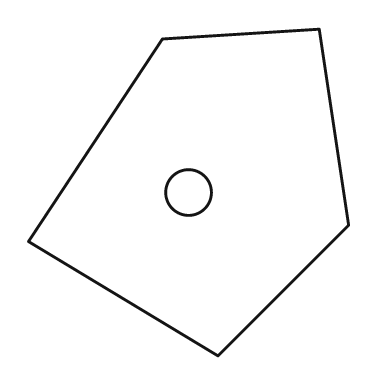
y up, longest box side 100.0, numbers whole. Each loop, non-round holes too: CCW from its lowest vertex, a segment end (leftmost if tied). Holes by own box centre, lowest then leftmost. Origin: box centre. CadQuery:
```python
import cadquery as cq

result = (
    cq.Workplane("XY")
    .moveTo(9.0, -50.0)
    .lineTo(49.0, -10.0)
    .lineTo(40.0, 50.0)
    .lineTo(-8.0, 47.0)
    .lineTo(-49.0, -15.0)
    .close()
    .moveTo(0.0, 0.0)
    .circle(7.0)
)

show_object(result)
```